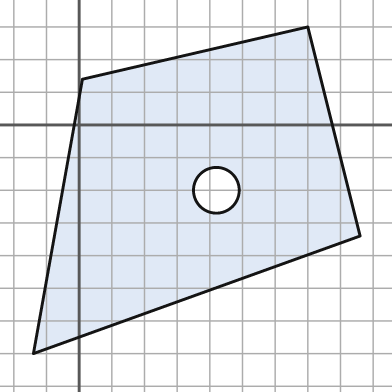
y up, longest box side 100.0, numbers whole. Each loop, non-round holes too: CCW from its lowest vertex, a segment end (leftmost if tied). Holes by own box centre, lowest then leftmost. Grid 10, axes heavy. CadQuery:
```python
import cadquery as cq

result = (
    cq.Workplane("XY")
    .moveTo(-14.0, -70.0)
    .lineTo(86.0, -34.0)
    .lineTo(70.0, 30.0)
    .lineTo(1.0, 14.0)
    .close()
    .moveTo(42.0, -20.0)
    .circle(7.0)
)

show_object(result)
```